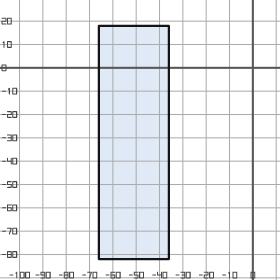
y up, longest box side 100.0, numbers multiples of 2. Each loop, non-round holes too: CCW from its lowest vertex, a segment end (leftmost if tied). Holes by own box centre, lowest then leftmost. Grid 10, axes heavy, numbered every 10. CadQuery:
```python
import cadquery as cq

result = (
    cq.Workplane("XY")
    .moveTo(-66.0, -82.0)
    .lineTo(-36.0, -82.0)
    .lineTo(-36.0, 18.0)
    .lineTo(-66.0, 18.0)
    .close()
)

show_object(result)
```